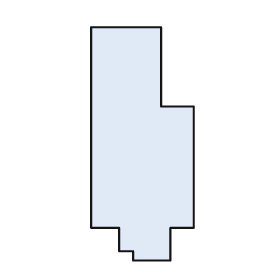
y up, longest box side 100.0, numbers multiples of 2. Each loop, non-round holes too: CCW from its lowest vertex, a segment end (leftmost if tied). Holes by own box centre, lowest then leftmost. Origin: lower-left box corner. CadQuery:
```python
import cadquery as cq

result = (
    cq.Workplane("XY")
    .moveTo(18.0, 0.0)
    .lineTo(34.0, 0.0)
    .lineTo(34.0, 14.0)
    .lineTo(44.0, 14.0)
    .lineTo(44.0, 66.0)
    .lineTo(30.0, 66.0)
    .lineTo(30.0, 100.0)
    .lineTo(0.0, 100.0)
    .lineTo(0.0, 14.0)
    .lineTo(12.0, 14.0)
    .lineTo(12.0, 4.0)
    .lineTo(18.0, 4.0)
    .close()
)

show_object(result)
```